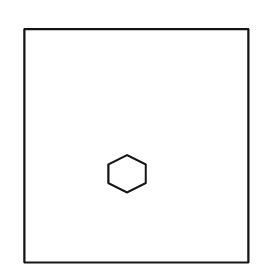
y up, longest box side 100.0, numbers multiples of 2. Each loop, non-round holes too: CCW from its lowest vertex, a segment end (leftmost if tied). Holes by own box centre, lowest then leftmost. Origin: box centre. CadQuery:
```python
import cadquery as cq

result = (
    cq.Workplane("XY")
    .moveTo(-48.0, -50.0)
    .lineTo(48.0, -50.0)
    .lineTo(48.0, 50.0)
    .lineTo(-48.0, 50.0)
    .close()
    .moveTo(-4.0, -20.0)
    .lineTo(4.0, -16.0)
    .lineTo(4.0, -8.0)
    .lineTo(-4.0, -4.0)
    .lineTo(-12.0, -8.0)
    .lineTo(-12.0, -16.0)
    .close()
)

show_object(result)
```